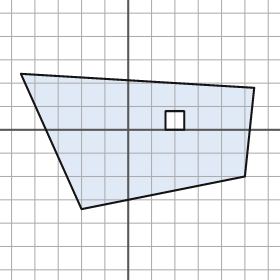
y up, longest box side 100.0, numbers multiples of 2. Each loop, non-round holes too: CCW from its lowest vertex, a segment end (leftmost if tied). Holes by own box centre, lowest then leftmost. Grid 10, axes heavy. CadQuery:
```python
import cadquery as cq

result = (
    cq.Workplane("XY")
    .moveTo(-20.0, -34.0)
    .lineTo(50.0, -20.0)
    .lineTo(54.0, 18.0)
    .lineTo(-46.0, 24.0)
    .close()
    .moveTo(16.0, 0.0)
    .lineTo(24.0, 0.0)
    .lineTo(24.0, 8.0)
    .lineTo(16.0, 8.0)
    .close()
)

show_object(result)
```